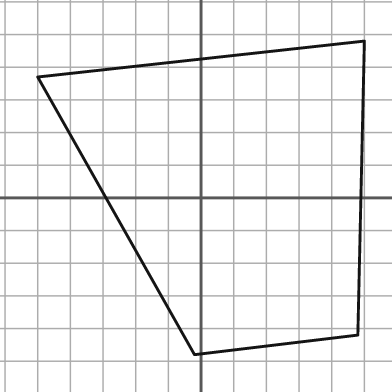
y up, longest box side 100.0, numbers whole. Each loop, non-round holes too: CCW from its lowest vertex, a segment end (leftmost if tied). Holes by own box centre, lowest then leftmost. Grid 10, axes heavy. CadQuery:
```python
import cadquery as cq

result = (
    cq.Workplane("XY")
    .moveTo(-2.0, -48.0)
    .lineTo(48.0, -42.0)
    .lineTo(50.0, 48.0)
    .lineTo(-50.0, 37.0)
    .close()
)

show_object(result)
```